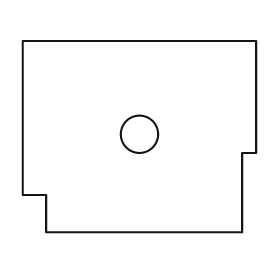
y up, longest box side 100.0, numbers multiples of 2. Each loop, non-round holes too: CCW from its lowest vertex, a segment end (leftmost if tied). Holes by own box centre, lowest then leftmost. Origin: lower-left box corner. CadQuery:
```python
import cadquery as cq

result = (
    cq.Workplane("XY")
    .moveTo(10.0, 0.0)
    .lineTo(94.0, 0.0)
    .lineTo(94.0, 34.0)
    .lineTo(100.0, 34.0)
    .lineTo(100.0, 82.0)
    .lineTo(0.0, 82.0)
    .lineTo(0.0, 16.0)
    .lineTo(10.0, 16.0)
    .close()
    .moveTo(50.0, 42.0)
    .circle(8.0)
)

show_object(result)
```